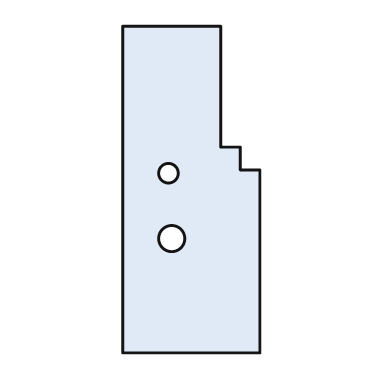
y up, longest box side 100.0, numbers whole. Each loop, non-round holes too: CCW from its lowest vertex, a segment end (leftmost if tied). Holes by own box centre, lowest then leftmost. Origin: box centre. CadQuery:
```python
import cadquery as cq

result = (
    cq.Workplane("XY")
    .moveTo(-21.0, -50.0)
    .lineTo(21.0, -50.0)
    .lineTo(21.0, 6.0)
    .lineTo(15.0, 6.0)
    .lineTo(15.0, 13.0)
    .lineTo(9.0, 13.0)
    .lineTo(9.0, 50.0)
    .lineTo(-21.0, 50.0)
    .close()
    .moveTo(-6.0, -15.0)
    .circle(4.0)
    .moveTo(-7.0, 5.0)
    .circle(3.0)
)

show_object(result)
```